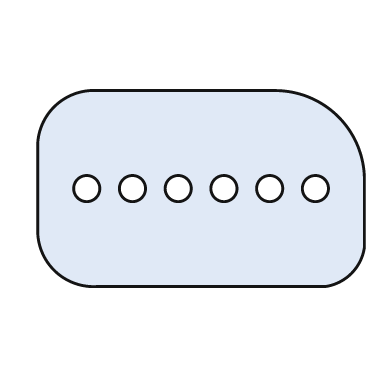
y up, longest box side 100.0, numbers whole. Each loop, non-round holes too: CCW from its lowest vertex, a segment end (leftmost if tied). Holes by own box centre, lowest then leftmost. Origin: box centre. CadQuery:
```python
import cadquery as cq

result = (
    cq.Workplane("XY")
    .moveTo(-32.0, -30.0)
    .lineTo(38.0, -30.0)
    .threePointArc((46.0, -26.0), (50.0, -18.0))
    .lineTo(50.0, 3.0)
    .threePointArc((42.0, 22.0), (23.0, 30.0))
    .lineTo(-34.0, 30.0)
    .threePointArc((-45.0, 25.0), (-50.0, 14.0))
    .lineTo(-50.0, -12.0)
    .threePointArc((-45.0, -25.0), (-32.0, -30.0))
    .close()
    .moveTo(-35.0, 0.0)
    .circle(4.0)
    .moveTo(-21.0, 0.0)
    .circle(4.0)
    .moveTo(-7.0, 0.0)
    .circle(4.0)
    .moveTo(7.0, 0.0)
    .circle(4.0)
    .moveTo(21.0, 0.0)
    .circle(4.0)
    .moveTo(35.0, 0.0)
    .circle(4.0)
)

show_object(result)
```